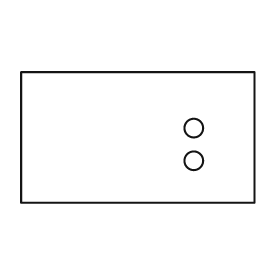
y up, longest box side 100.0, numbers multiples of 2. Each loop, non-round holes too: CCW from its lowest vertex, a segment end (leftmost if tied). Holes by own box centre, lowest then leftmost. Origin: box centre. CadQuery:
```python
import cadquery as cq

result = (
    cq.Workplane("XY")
    .moveTo(-50.0, -28.0)
    .lineTo(50.0, -28.0)
    .lineTo(50.0, 28.0)
    .lineTo(-50.0, 28.0)
    .close()
    .moveTo(24.0, -10.0)
    .circle(4.0)
    .moveTo(24.0, 4.0)
    .circle(4.0)
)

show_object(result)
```